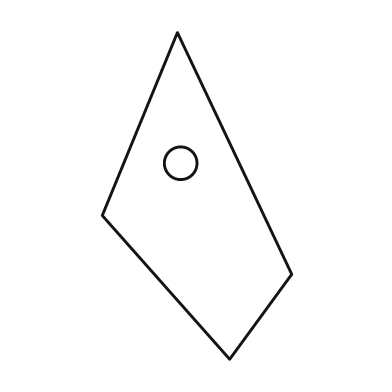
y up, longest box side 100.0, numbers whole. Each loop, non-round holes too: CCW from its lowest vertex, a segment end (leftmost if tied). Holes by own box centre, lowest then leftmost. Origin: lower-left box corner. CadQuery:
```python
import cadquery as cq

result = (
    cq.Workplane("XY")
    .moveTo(39.0, 0.0)
    .lineTo(58.0, 26.0)
    .lineTo(23.0, 100.0)
    .lineTo(0.0, 44.0)
    .close()
    .moveTo(24.0, 60.0)
    .circle(5.0)
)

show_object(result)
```